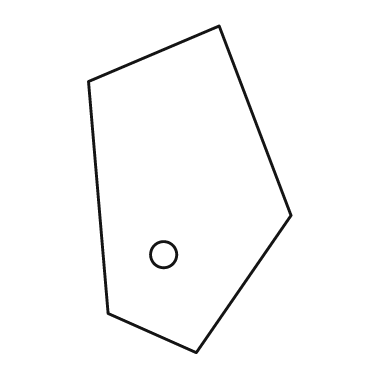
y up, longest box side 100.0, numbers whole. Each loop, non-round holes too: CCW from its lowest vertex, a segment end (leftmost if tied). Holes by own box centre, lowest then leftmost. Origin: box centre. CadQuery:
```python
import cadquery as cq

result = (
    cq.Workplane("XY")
    .moveTo(2.0, -50.0)
    .lineTo(31.0, -8.0)
    .lineTo(9.0, 50.0)
    .lineTo(-31.0, 33.0)
    .lineTo(-25.0, -38.0)
    .close()
    .moveTo(-8.0, -20.0)
    .circle(4.0)
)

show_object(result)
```